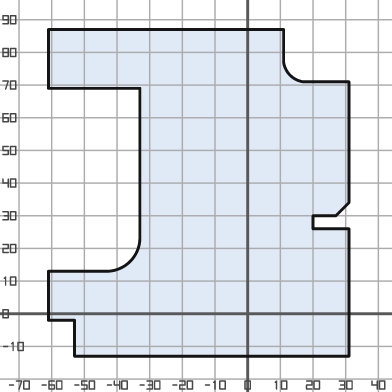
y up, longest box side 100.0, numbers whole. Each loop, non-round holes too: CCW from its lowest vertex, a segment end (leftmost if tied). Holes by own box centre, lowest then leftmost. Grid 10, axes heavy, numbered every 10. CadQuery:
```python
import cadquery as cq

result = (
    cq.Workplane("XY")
    .moveTo(-53.0, -13.0)
    .lineTo(31.0, -13.0)
    .lineTo(31.0, 26.0)
    .lineTo(20.0, 26.0)
    .lineTo(20.0, 30.0)
    .lineTo(27.0, 30.0)
    .lineTo(31.0, 34.0)
    .lineTo(31.0, 71.0)
    .lineTo(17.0, 71.0)
    .threePointArc((13.0, 73.0), (11.0, 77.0))
    .lineTo(11.0, 87.0)
    .lineTo(-61.0, 87.0)
    .lineTo(-61.0, 69.0)
    .lineTo(-33.0, 69.0)
    .lineTo(-33.0, 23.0)
    .threePointArc((-36.0, 16.0), (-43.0, 13.0))
    .lineTo(-61.0, 13.0)
    .lineTo(-61.0, -2.0)
    .lineTo(-53.0, -2.0)
    .close()
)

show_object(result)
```